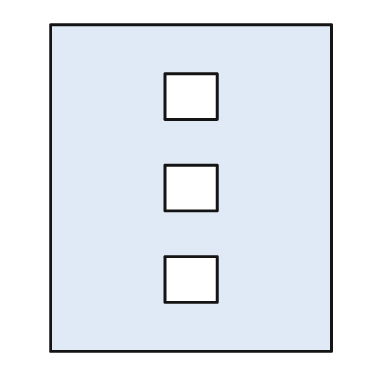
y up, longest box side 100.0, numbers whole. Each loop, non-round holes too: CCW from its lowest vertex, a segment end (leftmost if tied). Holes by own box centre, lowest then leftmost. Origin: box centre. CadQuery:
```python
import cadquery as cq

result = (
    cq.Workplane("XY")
    .moveTo(-43.0, -50.0)
    .lineTo(43.0, -50.0)
    .lineTo(43.0, 50.0)
    .lineTo(-43.0, 50.0)
    .close()
    .moveTo(-8.0, -35.0)
    .lineTo(8.0, -35.0)
    .lineTo(8.0, -21.0)
    .lineTo(-8.0, -21.0)
    .close()
    .moveTo(-8.0, -7.0)
    .lineTo(8.0, -7.0)
    .lineTo(8.0, 7.0)
    .lineTo(-8.0, 7.0)
    .close()
    .moveTo(-8.0, 21.0)
    .lineTo(8.0, 21.0)
    .lineTo(8.0, 35.0)
    .lineTo(-8.0, 35.0)
    .close()
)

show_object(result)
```